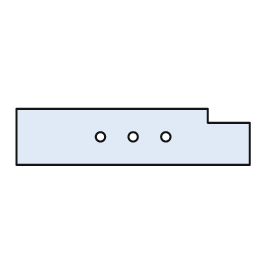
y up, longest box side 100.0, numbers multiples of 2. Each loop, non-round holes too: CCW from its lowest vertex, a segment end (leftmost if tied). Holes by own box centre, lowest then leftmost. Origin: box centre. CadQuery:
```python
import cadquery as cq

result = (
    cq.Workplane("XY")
    .moveTo(-50.0, -12.0)
    .lineTo(50.0, -12.0)
    .lineTo(50.0, 6.0)
    .lineTo(32.0, 6.0)
    .lineTo(32.0, 12.0)
    .lineTo(-50.0, 12.0)
    .close()
    .moveTo(-14.0, 0.0)
    .circle(2.0)
    .moveTo(0.0, 0.0)
    .circle(2.0)
    .moveTo(14.0, 0.0)
    .circle(2.0)
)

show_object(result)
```